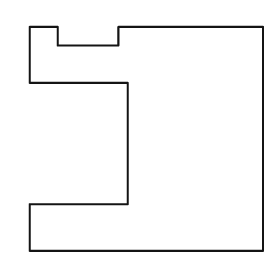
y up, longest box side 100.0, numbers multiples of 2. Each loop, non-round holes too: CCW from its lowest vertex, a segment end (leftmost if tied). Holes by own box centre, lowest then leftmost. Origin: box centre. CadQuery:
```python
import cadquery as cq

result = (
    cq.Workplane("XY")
    .moveTo(-50.0, -48.0)
    .lineTo(50.0, -48.0)
    .lineTo(50.0, 48.0)
    .lineTo(-12.0, 48.0)
    .lineTo(-12.0, 40.0)
    .lineTo(-38.0, 40.0)
    .lineTo(-38.0, 48.0)
    .lineTo(-50.0, 48.0)
    .lineTo(-50.0, 24.0)
    .lineTo(-8.0, 24.0)
    .lineTo(-8.0, -28.0)
    .lineTo(-50.0, -28.0)
    .close()
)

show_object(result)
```